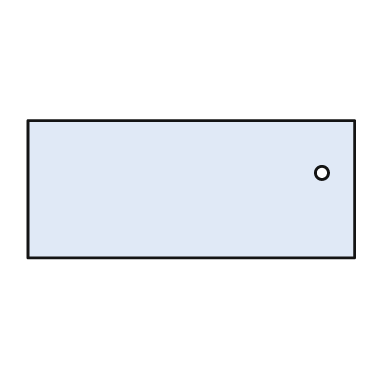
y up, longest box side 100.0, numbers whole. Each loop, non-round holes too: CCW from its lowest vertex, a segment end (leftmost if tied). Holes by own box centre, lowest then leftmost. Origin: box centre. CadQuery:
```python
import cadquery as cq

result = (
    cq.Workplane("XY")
    .moveTo(-50.0, -21.0)
    .lineTo(50.0, -21.0)
    .lineTo(50.0, 21.0)
    .lineTo(-50.0, 21.0)
    .close()
    .moveTo(40.0, 5.0)
    .circle(2.0)
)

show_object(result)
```